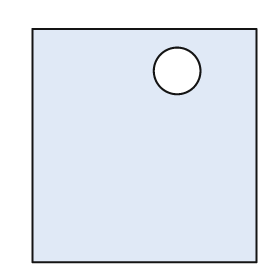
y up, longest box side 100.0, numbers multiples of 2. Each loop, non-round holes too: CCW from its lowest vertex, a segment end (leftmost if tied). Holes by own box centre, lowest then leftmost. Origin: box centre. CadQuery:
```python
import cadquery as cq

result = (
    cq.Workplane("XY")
    .moveTo(-48.0, -50.0)
    .lineTo(48.0, -50.0)
    .lineTo(48.0, 50.0)
    .lineTo(-48.0, 50.0)
    .close()
    .moveTo(14.0, 32.0)
    .circle(10.0)
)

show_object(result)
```